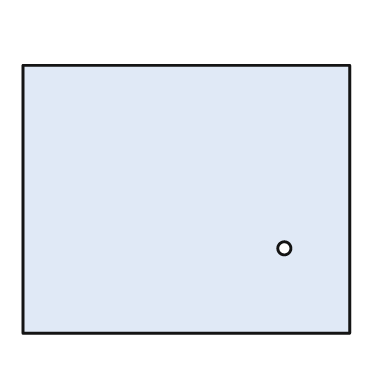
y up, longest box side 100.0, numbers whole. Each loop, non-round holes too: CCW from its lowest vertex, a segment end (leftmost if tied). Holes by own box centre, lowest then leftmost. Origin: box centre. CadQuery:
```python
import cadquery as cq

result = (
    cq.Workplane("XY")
    .moveTo(-50.0, -41.0)
    .lineTo(50.0, -41.0)
    .lineTo(50.0, 41.0)
    .lineTo(-50.0, 41.0)
    .close()
    .moveTo(30.0, -15.0)
    .circle(2.0)
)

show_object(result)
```